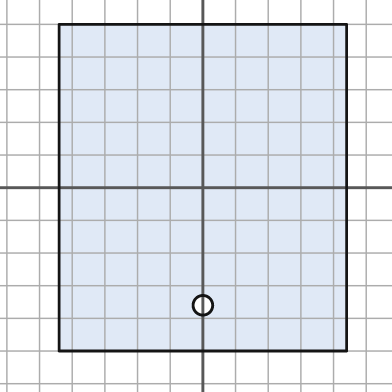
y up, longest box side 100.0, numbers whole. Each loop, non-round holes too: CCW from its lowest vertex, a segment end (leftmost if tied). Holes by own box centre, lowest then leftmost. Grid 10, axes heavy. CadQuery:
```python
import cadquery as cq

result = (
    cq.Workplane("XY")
    .moveTo(-44.0, -50.0)
    .lineTo(44.0, -50.0)
    .lineTo(44.0, 50.0)
    .lineTo(-44.0, 50.0)
    .close()
    .moveTo(0.0, -36.0)
    .circle(3.0)
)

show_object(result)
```